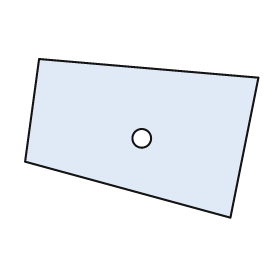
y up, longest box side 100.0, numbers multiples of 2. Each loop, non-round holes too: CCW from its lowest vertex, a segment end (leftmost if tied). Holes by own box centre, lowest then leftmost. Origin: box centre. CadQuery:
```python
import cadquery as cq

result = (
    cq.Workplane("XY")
    .moveTo(38.0, -34.0)
    .lineTo(50.0, 26.0)
    .lineTo(-44.0, 34.0)
    .lineTo(-50.0, -10.0)
    .close()
    .moveTo(0.0, 0.0)
    .circle(4.0)
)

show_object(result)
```